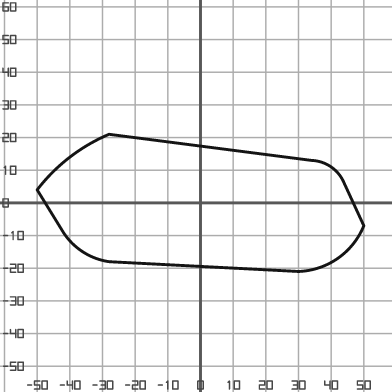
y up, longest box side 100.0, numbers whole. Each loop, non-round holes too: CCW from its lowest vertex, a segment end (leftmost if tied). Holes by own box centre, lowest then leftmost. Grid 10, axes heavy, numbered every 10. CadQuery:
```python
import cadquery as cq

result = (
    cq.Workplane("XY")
    .moveTo(30.0, -21.0)
    .threePointArc((42.0, -17.0), (50.0, -7.0))
    .lineTo(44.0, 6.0)
    .threePointArc((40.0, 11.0), (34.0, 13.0))
    .lineTo(-28.0, 21.0)
    .threePointArc((-40.0, 14.0), (-50.0, 4.0))
    .lineTo(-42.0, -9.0)
    .threePointArc((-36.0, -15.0), (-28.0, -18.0))
    .close()
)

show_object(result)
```